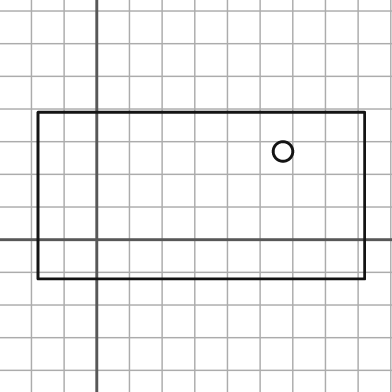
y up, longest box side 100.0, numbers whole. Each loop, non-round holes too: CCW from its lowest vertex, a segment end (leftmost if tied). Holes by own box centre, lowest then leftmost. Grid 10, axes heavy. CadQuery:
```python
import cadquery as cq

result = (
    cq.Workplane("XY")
    .moveTo(-18.0, -12.0)
    .lineTo(82.0, -12.0)
    .lineTo(82.0, 39.0)
    .lineTo(-18.0, 39.0)
    .close()
    .moveTo(57.0, 27.0)
    .circle(3.0)
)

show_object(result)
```